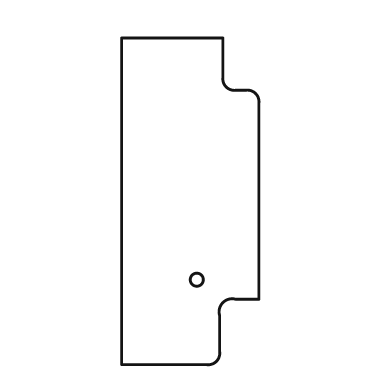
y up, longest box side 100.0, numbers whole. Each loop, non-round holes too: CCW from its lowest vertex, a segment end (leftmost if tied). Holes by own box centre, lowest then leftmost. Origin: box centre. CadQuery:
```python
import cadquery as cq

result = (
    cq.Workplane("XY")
    .moveTo(-21.0, -50.0)
    .lineTo(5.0, -50.0)
    .threePointArc((8.0, -49.0), (9.0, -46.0))
    .lineTo(9.0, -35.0)
    .threePointArc((10.0, -31.0), (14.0, -30.0))
    .lineTo(21.0, -30.0)
    .lineTo(21.0, 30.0)
    .threePointArc((20.0, 33.0), (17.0, 34.0))
    .lineTo(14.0, 34.0)
    .threePointArc((11.0, 35.0), (10.0, 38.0))
    .lineTo(10.0, 50.0)
    .lineTo(-21.0, 50.0)
    .close()
    .moveTo(2.0, -24.0)
    .circle(2.0)
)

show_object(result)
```